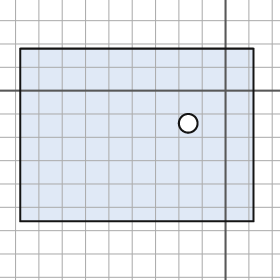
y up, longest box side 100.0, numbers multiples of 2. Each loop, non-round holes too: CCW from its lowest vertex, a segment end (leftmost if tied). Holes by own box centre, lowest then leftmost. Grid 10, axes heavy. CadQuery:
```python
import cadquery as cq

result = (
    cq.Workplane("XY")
    .moveTo(-88.0, -56.0)
    .lineTo(12.0, -56.0)
    .lineTo(12.0, 18.0)
    .lineTo(-88.0, 18.0)
    .close()
    .moveTo(-16.0, -14.0)
    .circle(4.0)
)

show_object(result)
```